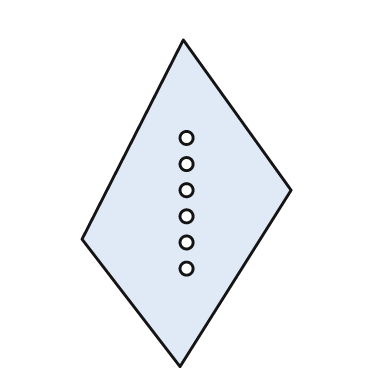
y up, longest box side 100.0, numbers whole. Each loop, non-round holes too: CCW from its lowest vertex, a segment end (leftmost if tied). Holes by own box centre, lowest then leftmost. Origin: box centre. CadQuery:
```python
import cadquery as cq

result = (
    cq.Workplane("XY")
    .moveTo(-2.0, -50.0)
    .lineTo(32.0, 4.0)
    .lineTo(-1.0, 50.0)
    .lineTo(-32.0, -11.0)
    .close()
    .moveTo(0.0, -20.0)
    .circle(2.0)
    .moveTo(0.0, -12.0)
    .circle(2.0)
    .moveTo(0.0, -4.0)
    .circle(2.0)
    .moveTo(0.0, 4.0)
    .circle(2.0)
    .moveTo(0.0, 12.0)
    .circle(2.0)
    .moveTo(0.0, 20.0)
    .circle(2.0)
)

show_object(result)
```